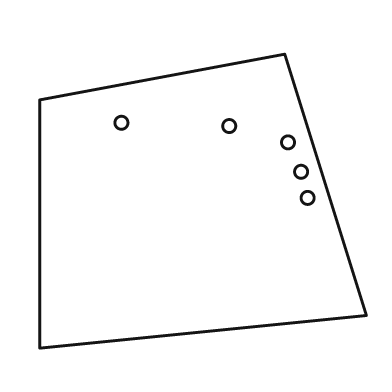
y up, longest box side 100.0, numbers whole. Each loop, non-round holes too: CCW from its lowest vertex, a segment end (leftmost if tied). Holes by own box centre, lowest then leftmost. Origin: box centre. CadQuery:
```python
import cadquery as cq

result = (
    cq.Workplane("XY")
    .moveTo(-50.0, -45.0)
    .lineTo(50.0, -35.0)
    .lineTo(25.0, 45.0)
    .lineTo(-50.0, 31.0)
    .close()
    .moveTo(32.0, 1.0)
    .circle(2.0)
    .moveTo(30.0, 9.0)
    .circle(2.0)
    .moveTo(26.0, 18.0)
    .circle(2.0)
    .moveTo(8.0, 23.0)
    .circle(2.0)
    .moveTo(-25.0, 24.0)
    .circle(2.0)
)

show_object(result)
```